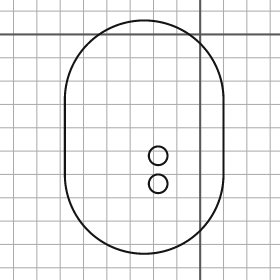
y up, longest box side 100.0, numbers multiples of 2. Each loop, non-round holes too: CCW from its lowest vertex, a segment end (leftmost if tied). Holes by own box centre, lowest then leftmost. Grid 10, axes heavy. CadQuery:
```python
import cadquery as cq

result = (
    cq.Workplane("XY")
    .moveTo(-58.0, -60.0)
    .threePointArc((-24.0, -94.0), (10.0, -60.0))
    .lineTo(10.0, -28.0)
    .threePointArc((-24.0, 6.0), (-58.0, -28.0))
    .close()
    .moveTo(-18.0, -64.0)
    .circle(4.0)
    .moveTo(-18.0, -52.0)
    .circle(4.0)
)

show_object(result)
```